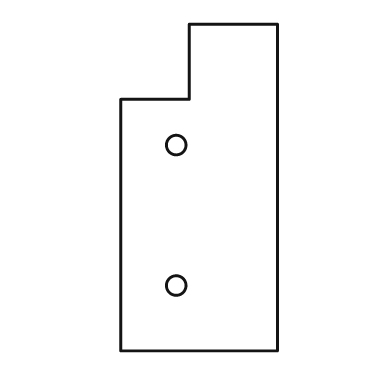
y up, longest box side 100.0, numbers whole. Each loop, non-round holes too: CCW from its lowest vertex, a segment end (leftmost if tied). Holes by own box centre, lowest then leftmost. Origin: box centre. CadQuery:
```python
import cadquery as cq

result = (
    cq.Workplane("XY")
    .moveTo(-24.0, -50.0)
    .lineTo(24.0, -50.0)
    .lineTo(24.0, 50.0)
    .lineTo(-3.0, 50.0)
    .lineTo(-3.0, 27.0)
    .lineTo(-24.0, 27.0)
    .close()
    .moveTo(-7.0, -30.0)
    .circle(3.0)
    .moveTo(-7.0, 13.0)
    .circle(3.0)
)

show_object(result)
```